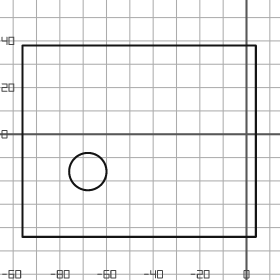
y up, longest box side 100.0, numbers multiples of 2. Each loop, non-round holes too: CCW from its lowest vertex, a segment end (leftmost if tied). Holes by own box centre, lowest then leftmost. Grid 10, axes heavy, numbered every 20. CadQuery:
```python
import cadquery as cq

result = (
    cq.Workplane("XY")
    .moveTo(-96.0, -44.0)
    .lineTo(4.0, -44.0)
    .lineTo(4.0, 38.0)
    .lineTo(-96.0, 38.0)
    .close()
    .moveTo(-68.0, -16.0)
    .circle(8.0)
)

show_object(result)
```